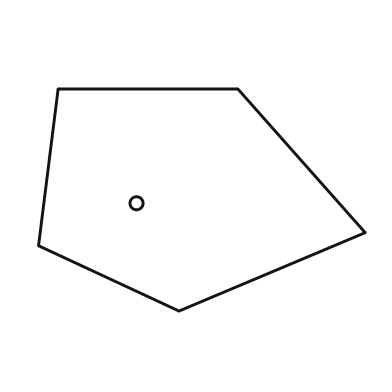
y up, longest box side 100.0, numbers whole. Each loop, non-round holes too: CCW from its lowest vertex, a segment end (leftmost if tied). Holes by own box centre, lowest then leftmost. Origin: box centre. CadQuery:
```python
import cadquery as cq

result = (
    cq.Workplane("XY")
    .moveTo(-7.0, -34.0)
    .lineTo(50.0, -10.0)
    .lineTo(11.0, 34.0)
    .lineTo(-44.0, 34.0)
    .lineTo(-50.0, -14.0)
    .close()
    .moveTo(-20.0, -1.0)
    .circle(2.0)
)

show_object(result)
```